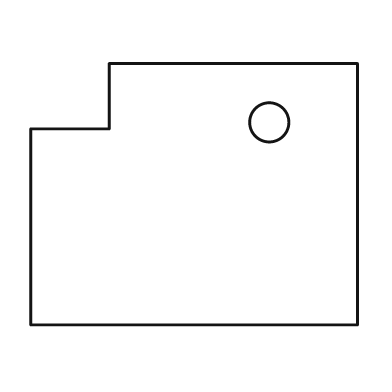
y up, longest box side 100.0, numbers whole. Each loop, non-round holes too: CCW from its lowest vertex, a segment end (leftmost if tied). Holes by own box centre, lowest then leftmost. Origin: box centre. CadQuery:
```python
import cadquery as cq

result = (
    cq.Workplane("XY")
    .moveTo(-50.0, -40.0)
    .lineTo(50.0, -40.0)
    .lineTo(50.0, 40.0)
    .lineTo(-26.0, 40.0)
    .lineTo(-26.0, 20.0)
    .lineTo(-50.0, 20.0)
    .close()
    .moveTo(23.0, 22.0)
    .circle(6.0)
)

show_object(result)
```